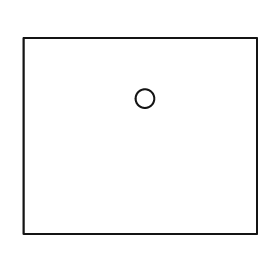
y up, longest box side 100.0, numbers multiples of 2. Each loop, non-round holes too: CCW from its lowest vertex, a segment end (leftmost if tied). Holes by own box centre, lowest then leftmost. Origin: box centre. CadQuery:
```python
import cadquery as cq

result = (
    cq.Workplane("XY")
    .moveTo(-50.0, -42.0)
    .lineTo(50.0, -42.0)
    .lineTo(50.0, 42.0)
    .lineTo(-50.0, 42.0)
    .close()
    .moveTo(2.0, 16.0)
    .circle(4.0)
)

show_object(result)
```